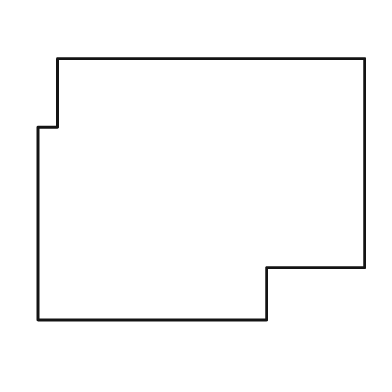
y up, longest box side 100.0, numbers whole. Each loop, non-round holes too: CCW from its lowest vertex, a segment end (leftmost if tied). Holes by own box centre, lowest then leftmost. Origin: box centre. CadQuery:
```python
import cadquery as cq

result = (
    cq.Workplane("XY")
    .moveTo(-50.0, -40.0)
    .lineTo(20.0, -40.0)
    .lineTo(20.0, -24.0)
    .lineTo(50.0, -24.0)
    .lineTo(50.0, 40.0)
    .lineTo(-44.0, 40.0)
    .lineTo(-44.0, 19.0)
    .lineTo(-50.0, 19.0)
    .close()
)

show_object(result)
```